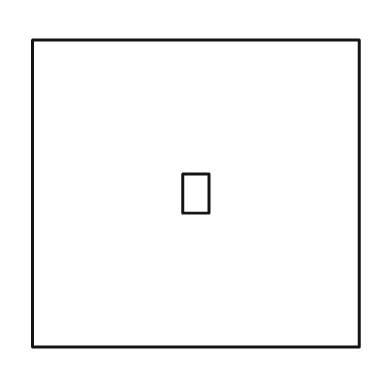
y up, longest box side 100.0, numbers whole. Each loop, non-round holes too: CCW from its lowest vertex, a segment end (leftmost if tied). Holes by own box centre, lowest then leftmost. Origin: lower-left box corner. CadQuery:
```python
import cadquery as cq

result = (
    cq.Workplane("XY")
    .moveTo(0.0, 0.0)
    .lineTo(100.0, 0.0)
    .lineTo(100.0, 94.0)
    .lineTo(0.0, 94.0)
    .close()
    .moveTo(46.0, 41.0)
    .lineTo(54.0, 41.0)
    .lineTo(54.0, 53.0)
    .lineTo(46.0, 53.0)
    .close()
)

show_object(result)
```